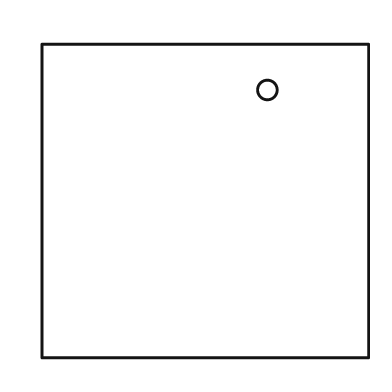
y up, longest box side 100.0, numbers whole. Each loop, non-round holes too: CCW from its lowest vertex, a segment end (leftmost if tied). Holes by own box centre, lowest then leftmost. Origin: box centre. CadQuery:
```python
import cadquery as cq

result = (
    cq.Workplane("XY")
    .moveTo(-50.0, -48.0)
    .lineTo(50.0, -48.0)
    .lineTo(50.0, 48.0)
    .lineTo(-50.0, 48.0)
    .close()
    .moveTo(19.0, 34.0)
    .circle(3.0)
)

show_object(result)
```